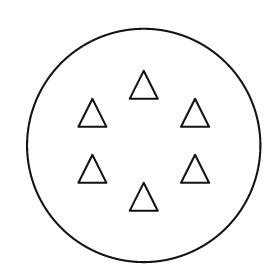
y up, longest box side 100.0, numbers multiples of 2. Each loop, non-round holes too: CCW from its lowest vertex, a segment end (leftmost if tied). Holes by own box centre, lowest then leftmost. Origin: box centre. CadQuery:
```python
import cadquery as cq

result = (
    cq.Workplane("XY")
    .moveTo(0.0, 0.0)
    .circle(50.0)
    .moveTo(-6.0, -28.0)
    .lineTo(6.0, -28.0)
    .lineTo(0.0, -16.0)
    .close()
    .moveTo(-28.0, -16.0)
    .lineTo(-16.0, -16.0)
    .lineTo(-22.0, -4.0)
    .close()
    .moveTo(16.0, -16.0)
    .lineTo(28.0, -16.0)
    .lineTo(22.0, -4.0)
    .close()
    .moveTo(-28.0, 8.0)
    .lineTo(-16.0, 8.0)
    .lineTo(-22.0, 20.0)
    .close()
    .moveTo(16.0, 8.0)
    .lineTo(28.0, 8.0)
    .lineTo(22.0, 20.0)
    .close()
    .moveTo(-6.0, 20.0)
    .lineTo(6.0, 20.0)
    .lineTo(0.0, 32.0)
    .close()
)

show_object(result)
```